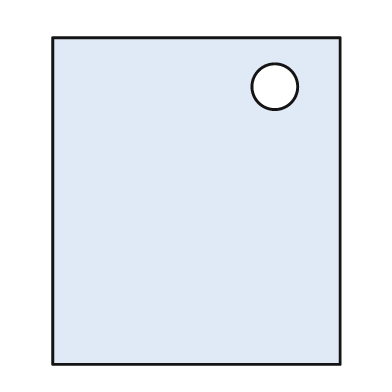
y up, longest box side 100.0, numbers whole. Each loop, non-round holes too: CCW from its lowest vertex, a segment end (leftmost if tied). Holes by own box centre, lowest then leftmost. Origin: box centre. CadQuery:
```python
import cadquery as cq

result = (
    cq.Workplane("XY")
    .moveTo(-44.0, -50.0)
    .lineTo(44.0, -50.0)
    .lineTo(44.0, 50.0)
    .lineTo(-44.0, 50.0)
    .close()
    .moveTo(24.0, 35.0)
    .circle(7.0)
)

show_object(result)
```